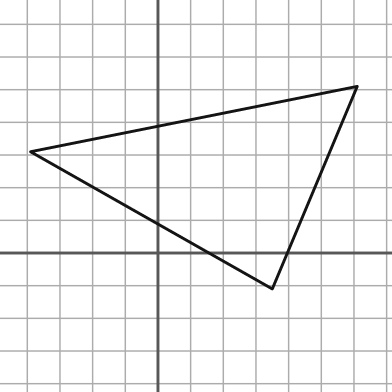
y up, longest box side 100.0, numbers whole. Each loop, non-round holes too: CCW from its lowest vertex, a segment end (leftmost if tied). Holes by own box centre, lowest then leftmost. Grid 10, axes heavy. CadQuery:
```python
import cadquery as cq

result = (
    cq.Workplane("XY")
    .moveTo(35.0, -11.0)
    .lineTo(61.0, 51.0)
    .lineTo(-39.0, 31.0)
    .close()
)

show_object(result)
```